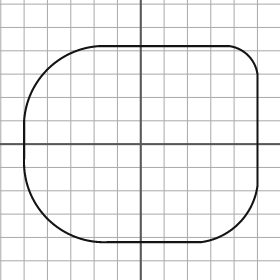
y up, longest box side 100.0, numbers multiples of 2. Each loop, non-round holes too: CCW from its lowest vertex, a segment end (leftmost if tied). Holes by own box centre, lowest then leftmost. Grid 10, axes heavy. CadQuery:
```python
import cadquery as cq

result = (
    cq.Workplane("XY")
    .moveTo(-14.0, -42.0)
    .lineTo(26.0, -42.0)
    .threePointArc((42.0, -34.0), (50.0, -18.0))
    .lineTo(50.0, 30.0)
    .threePointArc((46.0, 38.0), (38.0, 42.0))
    .lineTo(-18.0, 42.0)
    .threePointArc((-40.0, 32.0), (-50.0, 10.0))
    .lineTo(-50.0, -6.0)
    .threePointArc((-40.0, -32.0), (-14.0, -42.0))
    .close()
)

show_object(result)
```